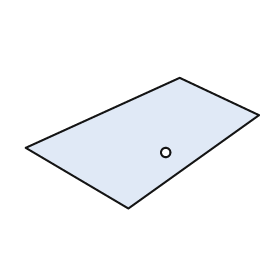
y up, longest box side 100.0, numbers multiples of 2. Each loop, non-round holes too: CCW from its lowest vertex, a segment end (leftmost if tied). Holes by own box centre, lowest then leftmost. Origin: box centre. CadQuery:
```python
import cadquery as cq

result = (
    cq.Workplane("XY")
    .moveTo(-6.0, -28.0)
    .lineTo(50.0, 12.0)
    .lineTo(16.0, 28.0)
    .lineTo(-50.0, -2.0)
    .close()
    .moveTo(10.0, -4.0)
    .circle(2.0)
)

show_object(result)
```